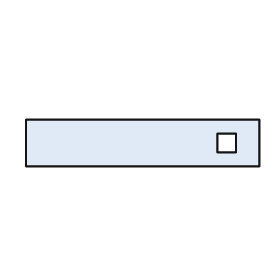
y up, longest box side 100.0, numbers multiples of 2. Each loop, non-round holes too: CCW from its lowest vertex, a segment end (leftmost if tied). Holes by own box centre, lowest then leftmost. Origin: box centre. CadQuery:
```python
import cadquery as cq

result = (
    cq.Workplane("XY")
    .moveTo(-50.0, -10.0)
    .lineTo(50.0, -10.0)
    .lineTo(50.0, 10.0)
    .lineTo(-50.0, 10.0)
    .close()
    .moveTo(32.0, -4.0)
    .lineTo(40.0, -4.0)
    .lineTo(40.0, 4.0)
    .lineTo(32.0, 4.0)
    .close()
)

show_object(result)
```